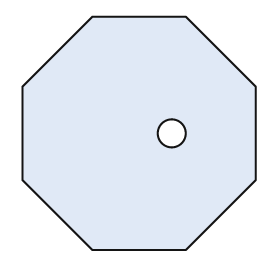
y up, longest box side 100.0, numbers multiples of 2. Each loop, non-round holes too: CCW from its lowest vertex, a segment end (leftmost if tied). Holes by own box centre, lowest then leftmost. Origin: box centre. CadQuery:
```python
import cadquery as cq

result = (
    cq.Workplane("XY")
    .moveTo(-20.0, -50.0)
    .lineTo(20.0, -50.0)
    .lineTo(50.0, -20.0)
    .lineTo(50.0, 20.0)
    .lineTo(20.0, 50.0)
    .lineTo(-20.0, 50.0)
    .lineTo(-50.0, 20.0)
    .lineTo(-50.0, -20.0)
    .close()
    .moveTo(14.0, 0.0)
    .circle(6.0)
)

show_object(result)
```